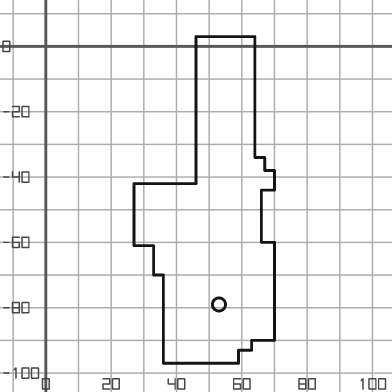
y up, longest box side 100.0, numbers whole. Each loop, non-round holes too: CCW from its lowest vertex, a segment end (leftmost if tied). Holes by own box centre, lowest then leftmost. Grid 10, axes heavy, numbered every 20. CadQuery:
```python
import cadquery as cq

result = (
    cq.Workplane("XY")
    .moveTo(36.0, -97.0)
    .lineTo(59.0, -97.0)
    .lineTo(59.0, -93.0)
    .lineTo(63.0, -93.0)
    .lineTo(63.0, -90.0)
    .lineTo(70.0, -90.0)
    .lineTo(70.0, -60.0)
    .lineTo(66.0, -60.0)
    .lineTo(66.0, -44.0)
    .lineTo(70.0, -44.0)
    .lineTo(70.0, -38.0)
    .lineTo(67.0, -38.0)
    .lineTo(67.0, -34.0)
    .lineTo(64.0, -34.0)
    .lineTo(64.0, 3.0)
    .lineTo(46.0, 3.0)
    .lineTo(46.0, -42.0)
    .lineTo(27.0, -42.0)
    .lineTo(27.0, -61.0)
    .lineTo(33.0, -61.0)
    .lineTo(33.0, -70.0)
    .lineTo(36.0, -70.0)
    .close()
    .moveTo(53.0, -79.0)
    .circle(2.0)
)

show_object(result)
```